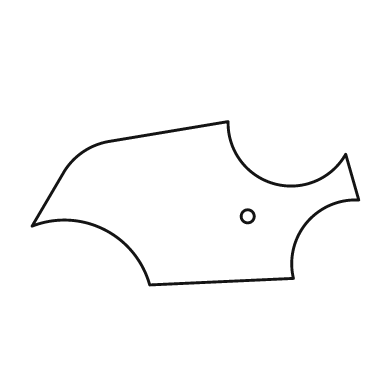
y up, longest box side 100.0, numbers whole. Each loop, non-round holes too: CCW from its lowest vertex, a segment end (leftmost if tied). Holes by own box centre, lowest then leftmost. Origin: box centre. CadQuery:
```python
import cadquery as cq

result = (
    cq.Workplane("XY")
    .moveTo(-14.0, -25.0)
    .lineTo(30.0, -23.0)
    .threePointArc((34.0, -6.0), (50.0, 1.0))
    .lineTo(46.0, 15.0)
    .threePointArc((24.0, 6.0), (10.0, 25.0))
    .lineTo(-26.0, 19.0)
    .threePointArc((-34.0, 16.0), (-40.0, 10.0))
    .lineTo(-50.0, -7.0)
    .threePointArc((-28.0, -8.0), (-14.0, -25.0))
    .close()
    .moveTo(16.0, -4.0)
    .circle(2.0)
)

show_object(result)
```